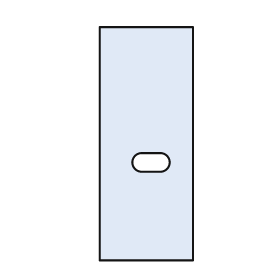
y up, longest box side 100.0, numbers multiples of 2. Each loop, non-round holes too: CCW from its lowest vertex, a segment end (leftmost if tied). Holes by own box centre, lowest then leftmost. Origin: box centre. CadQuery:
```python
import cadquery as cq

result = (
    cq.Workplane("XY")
    .moveTo(-20.0, -50.0)
    .lineTo(20.0, -50.0)
    .lineTo(20.0, 50.0)
    .lineTo(-20.0, 50.0)
    .close()
    .moveTo(-2.0, -12.0)
    .lineTo(6.0, -12.0)
    .threePointArc((10.0, -8.0), (6.0, -4.0))
    .lineTo(-2.0, -4.0)
    .threePointArc((-6.0, -8.0), (-2.0, -12.0))
    .close()
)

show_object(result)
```